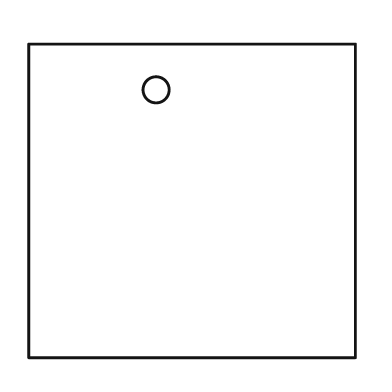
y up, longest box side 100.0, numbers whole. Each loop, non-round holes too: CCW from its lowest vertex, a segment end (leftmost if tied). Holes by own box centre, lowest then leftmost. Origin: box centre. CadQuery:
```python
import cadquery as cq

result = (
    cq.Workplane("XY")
    .moveTo(-50.0, -48.0)
    .lineTo(50.0, -48.0)
    .lineTo(50.0, 48.0)
    .lineTo(-50.0, 48.0)
    .close()
    .moveTo(-11.0, 34.0)
    .circle(4.0)
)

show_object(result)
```